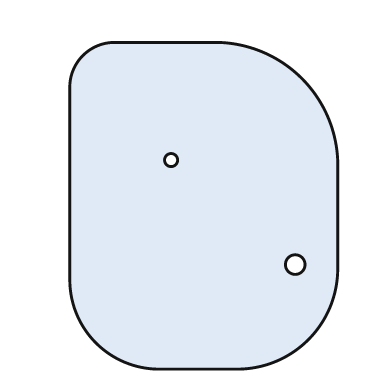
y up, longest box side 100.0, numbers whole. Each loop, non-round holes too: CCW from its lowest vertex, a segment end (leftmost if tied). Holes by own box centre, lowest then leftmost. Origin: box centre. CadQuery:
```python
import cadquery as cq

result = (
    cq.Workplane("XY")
    .moveTo(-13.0, -50.0)
    .lineTo(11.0, -50.0)
    .threePointArc((32.0, -41.0), (41.0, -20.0))
    .lineTo(41.0, 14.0)
    .threePointArc((30.0, 39.0), (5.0, 50.0))
    .lineTo(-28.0, 50.0)
    .threePointArc((-37.0, 46.0), (-41.0, 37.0))
    .lineTo(-41.0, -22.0)
    .threePointArc((-33.0, -42.0), (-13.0, -50.0))
    .close()
    .moveTo(28.0, -18.0)
    .circle(3.0)
    .moveTo(-10.0, 14.0)
    .circle(2.0)
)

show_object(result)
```